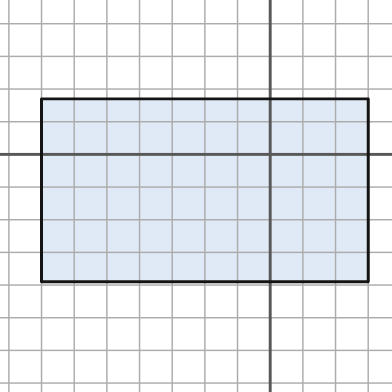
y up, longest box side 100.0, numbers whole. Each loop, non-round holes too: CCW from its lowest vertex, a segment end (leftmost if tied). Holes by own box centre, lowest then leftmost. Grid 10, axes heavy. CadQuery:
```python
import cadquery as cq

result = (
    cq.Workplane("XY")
    .moveTo(-70.0, -39.0)
    .lineTo(30.0, -39.0)
    .lineTo(30.0, 17.0)
    .lineTo(-70.0, 17.0)
    .close()
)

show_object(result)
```